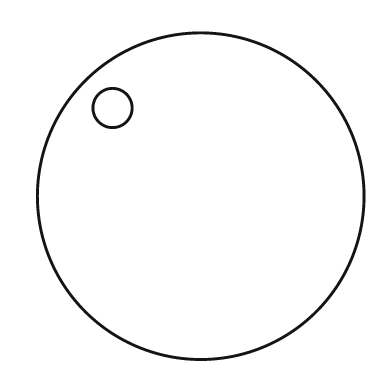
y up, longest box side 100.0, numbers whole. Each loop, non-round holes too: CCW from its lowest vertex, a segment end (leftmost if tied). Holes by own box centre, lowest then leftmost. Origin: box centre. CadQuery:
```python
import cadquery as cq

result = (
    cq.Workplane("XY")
    .moveTo(0.0, 0.0)
    .circle(50.0)
    .moveTo(-27.0, 27.0)
    .circle(6.0)
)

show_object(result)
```